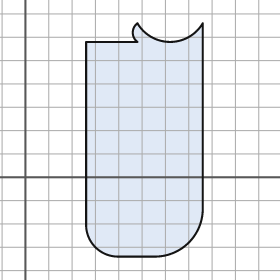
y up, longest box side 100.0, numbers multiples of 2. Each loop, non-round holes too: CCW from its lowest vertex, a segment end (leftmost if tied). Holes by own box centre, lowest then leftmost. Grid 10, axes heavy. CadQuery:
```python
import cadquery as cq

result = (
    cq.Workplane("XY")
    .moveTo(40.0, -34.0)
    .lineTo(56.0, -34.0)
    .threePointArc((70.0, -28.0), (76.0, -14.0))
    .lineTo(76.0, 66.0)
    .threePointArc((62.0, 58.0), (48.0, 66.0))
    .threePointArc((46.0, 62.0), (48.0, 58.0))
    .lineTo(26.0, 58.0)
    .lineTo(26.0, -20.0)
    .threePointArc((30.0, -30.0), (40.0, -34.0))
    .close()
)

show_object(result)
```